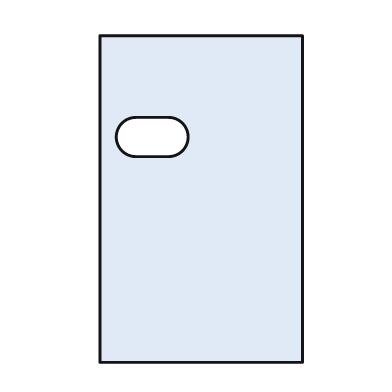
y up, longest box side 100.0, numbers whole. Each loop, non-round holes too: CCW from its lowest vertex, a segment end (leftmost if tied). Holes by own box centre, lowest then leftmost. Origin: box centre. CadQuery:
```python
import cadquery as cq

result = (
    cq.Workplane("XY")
    .moveTo(-31.0, -50.0)
    .lineTo(31.0, -50.0)
    .lineTo(31.0, 50.0)
    .lineTo(-31.0, 50.0)
    .close()
    .moveTo(-20.0, 13.0)
    .lineTo(-10.0, 13.0)
    .threePointArc((-4.0, 19.0), (-10.0, 25.0))
    .lineTo(-20.0, 25.0)
    .threePointArc((-26.0, 19.0), (-20.0, 13.0))
    .close()
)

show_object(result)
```